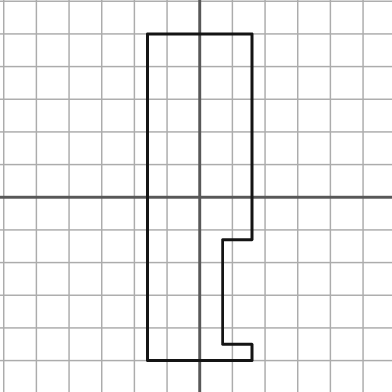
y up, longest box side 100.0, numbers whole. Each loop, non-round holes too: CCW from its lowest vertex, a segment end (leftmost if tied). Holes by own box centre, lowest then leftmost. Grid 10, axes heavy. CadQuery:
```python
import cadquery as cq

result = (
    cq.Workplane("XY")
    .moveTo(-16.0, -50.0)
    .lineTo(16.0, -50.0)
    .lineTo(16.0, -45.0)
    .lineTo(7.0, -45.0)
    .lineTo(7.0, -13.0)
    .lineTo(16.0, -13.0)
    .lineTo(16.0, 50.0)
    .lineTo(-16.0, 50.0)
    .close()
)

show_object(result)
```